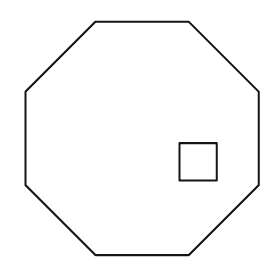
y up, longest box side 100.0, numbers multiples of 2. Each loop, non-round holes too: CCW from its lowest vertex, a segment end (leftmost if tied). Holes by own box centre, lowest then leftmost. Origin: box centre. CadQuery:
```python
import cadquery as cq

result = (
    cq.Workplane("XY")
    .moveTo(-20.0, -50.0)
    .lineTo(20.0, -50.0)
    .lineTo(50.0, -20.0)
    .lineTo(50.0, 20.0)
    .lineTo(20.0, 50.0)
    .lineTo(-20.0, 50.0)
    .lineTo(-50.0, 20.0)
    .lineTo(-50.0, -20.0)
    .close()
    .moveTo(16.0, -18.0)
    .lineTo(32.0, -18.0)
    .lineTo(32.0, -2.0)
    .lineTo(16.0, -2.0)
    .close()
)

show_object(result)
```